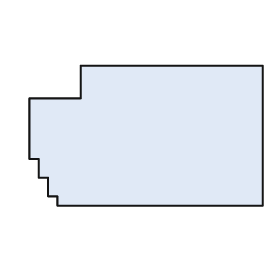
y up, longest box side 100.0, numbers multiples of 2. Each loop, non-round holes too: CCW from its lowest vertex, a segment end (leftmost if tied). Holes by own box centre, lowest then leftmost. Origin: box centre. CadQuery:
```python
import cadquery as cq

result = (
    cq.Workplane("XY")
    .moveTo(-38.0, -30.0)
    .lineTo(50.0, -30.0)
    .lineTo(50.0, 30.0)
    .lineTo(-28.0, 30.0)
    .lineTo(-28.0, 16.0)
    .lineTo(-50.0, 16.0)
    .lineTo(-50.0, -10.0)
    .lineTo(-46.0, -10.0)
    .lineTo(-46.0, -18.0)
    .lineTo(-42.0, -18.0)
    .lineTo(-42.0, -26.0)
    .lineTo(-38.0, -26.0)
    .close()
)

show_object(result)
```